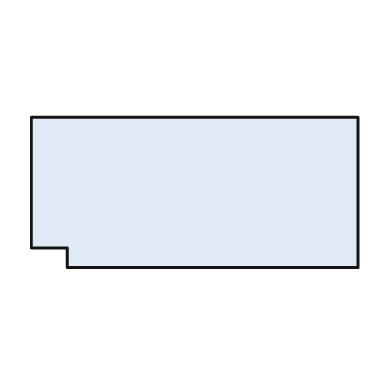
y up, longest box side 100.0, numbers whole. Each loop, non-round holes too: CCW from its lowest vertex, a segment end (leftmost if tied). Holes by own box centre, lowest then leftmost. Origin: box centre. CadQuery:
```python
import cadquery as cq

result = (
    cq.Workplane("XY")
    .moveTo(-39.0, -23.0)
    .lineTo(50.0, -23.0)
    .lineTo(50.0, 23.0)
    .lineTo(-50.0, 23.0)
    .lineTo(-50.0, -17.0)
    .lineTo(-39.0, -17.0)
    .close()
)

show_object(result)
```